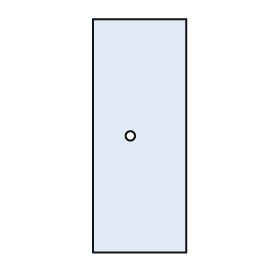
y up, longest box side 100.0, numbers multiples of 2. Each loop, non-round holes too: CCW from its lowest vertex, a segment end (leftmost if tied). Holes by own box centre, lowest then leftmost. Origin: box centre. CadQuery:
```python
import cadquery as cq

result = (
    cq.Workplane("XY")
    .moveTo(-20.0, -50.0)
    .lineTo(20.0, -50.0)
    .lineTo(20.0, 50.0)
    .lineTo(-20.0, 50.0)
    .close()
    .moveTo(-4.0, 0.0)
    .circle(2.0)
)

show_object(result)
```